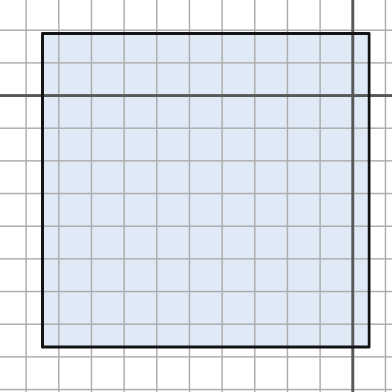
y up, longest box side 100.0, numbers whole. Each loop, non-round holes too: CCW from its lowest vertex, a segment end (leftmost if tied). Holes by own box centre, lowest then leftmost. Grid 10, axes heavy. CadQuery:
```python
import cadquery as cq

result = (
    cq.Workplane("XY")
    .moveTo(-95.0, -77.0)
    .lineTo(5.0, -77.0)
    .lineTo(5.0, 19.0)
    .lineTo(-95.0, 19.0)
    .close()
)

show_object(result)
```